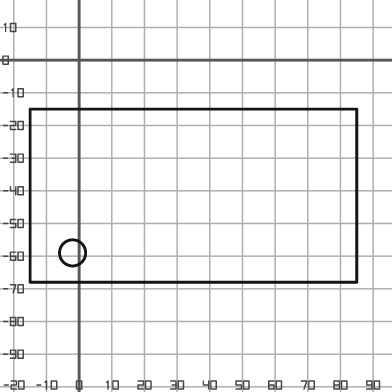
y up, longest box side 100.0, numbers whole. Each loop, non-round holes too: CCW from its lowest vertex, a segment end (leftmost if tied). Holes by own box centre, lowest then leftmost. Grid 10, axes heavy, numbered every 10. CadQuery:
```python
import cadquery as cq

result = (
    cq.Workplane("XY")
    .moveTo(-15.0, -68.0)
    .lineTo(85.0, -68.0)
    .lineTo(85.0, -15.0)
    .lineTo(-15.0, -15.0)
    .close()
    .moveTo(-2.0, -59.0)
    .circle(4.0)
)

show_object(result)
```